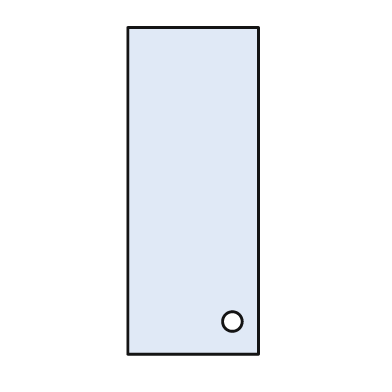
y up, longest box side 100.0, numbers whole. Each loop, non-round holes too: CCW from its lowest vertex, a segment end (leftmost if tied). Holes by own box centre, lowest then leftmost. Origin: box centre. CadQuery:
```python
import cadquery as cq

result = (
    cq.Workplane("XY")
    .moveTo(-20.0, -50.0)
    .lineTo(20.0, -50.0)
    .lineTo(20.0, 50.0)
    .lineTo(-20.0, 50.0)
    .close()
    .moveTo(12.0, -40.0)
    .circle(3.0)
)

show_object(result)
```